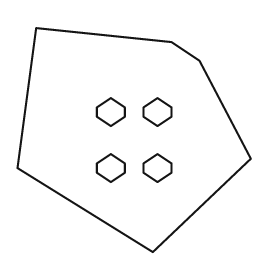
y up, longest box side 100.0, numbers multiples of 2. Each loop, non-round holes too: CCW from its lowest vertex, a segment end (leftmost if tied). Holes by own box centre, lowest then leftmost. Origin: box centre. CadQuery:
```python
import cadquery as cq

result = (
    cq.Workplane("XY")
    .moveTo(8.0, -48.0)
    .lineTo(50.0, -8.0)
    .lineTo(28.0, 34.0)
    .lineTo(16.0, 42.0)
    .lineTo(-42.0, 48.0)
    .lineTo(-50.0, -12.0)
    .close()
    .moveTo(-10.0, -18.0)
    .lineTo(-4.0, -14.0)
    .lineTo(-4.0, -10.0)
    .lineTo(-10.0, -6.0)
    .lineTo(-16.0, -10.0)
    .lineTo(-16.0, -14.0)
    .close()
    .moveTo(10.0, -18.0)
    .lineTo(16.0, -14.0)
    .lineTo(16.0, -10.0)
    .lineTo(10.0, -6.0)
    .lineTo(4.0, -10.0)
    .lineTo(4.0, -14.0)
    .close()
    .moveTo(-10.0, 6.0)
    .lineTo(-4.0, 10.0)
    .lineTo(-4.0, 14.0)
    .lineTo(-10.0, 18.0)
    .lineTo(-16.0, 14.0)
    .lineTo(-16.0, 10.0)
    .close()
    .moveTo(10.0, 6.0)
    .lineTo(16.0, 10.0)
    .lineTo(16.0, 14.0)
    .lineTo(10.0, 18.0)
    .lineTo(4.0, 14.0)
    .lineTo(4.0, 10.0)
    .close()
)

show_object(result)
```